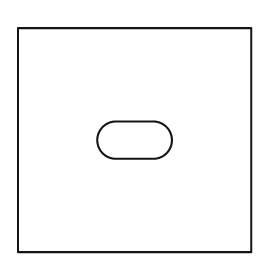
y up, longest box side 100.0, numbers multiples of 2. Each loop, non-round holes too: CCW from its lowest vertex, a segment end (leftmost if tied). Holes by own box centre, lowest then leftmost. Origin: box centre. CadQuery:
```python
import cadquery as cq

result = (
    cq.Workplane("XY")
    .moveTo(-50.0, -48.0)
    .lineTo(50.0, -48.0)
    .lineTo(50.0, 48.0)
    .lineTo(-50.0, 48.0)
    .close()
    .moveTo(-8.0, -8.0)
    .lineTo(8.0, -8.0)
    .threePointArc((16.0, 0.0), (8.0, 8.0))
    .lineTo(-8.0, 8.0)
    .threePointArc((-16.0, 0.0), (-8.0, -8.0))
    .close()
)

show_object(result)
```